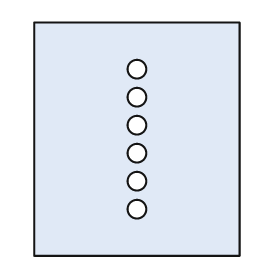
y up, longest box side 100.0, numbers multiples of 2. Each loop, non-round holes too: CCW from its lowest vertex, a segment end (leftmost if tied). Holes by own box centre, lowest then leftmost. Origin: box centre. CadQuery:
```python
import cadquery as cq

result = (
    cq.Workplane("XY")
    .moveTo(-44.0, -50.0)
    .lineTo(44.0, -50.0)
    .lineTo(44.0, 50.0)
    .lineTo(-44.0, 50.0)
    .close()
    .moveTo(0.0, -30.0)
    .circle(4.0)
    .moveTo(0.0, -18.0)
    .circle(4.0)
    .moveTo(0.0, -6.0)
    .circle(4.0)
    .moveTo(0.0, 6.0)
    .circle(4.0)
    .moveTo(0.0, 18.0)
    .circle(4.0)
    .moveTo(0.0, 30.0)
    .circle(4.0)
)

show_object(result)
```